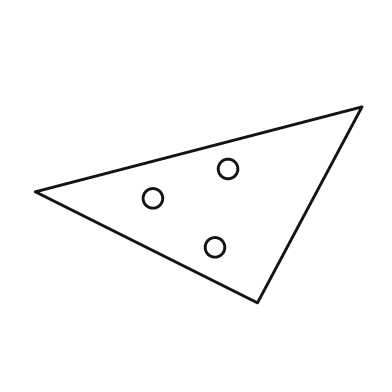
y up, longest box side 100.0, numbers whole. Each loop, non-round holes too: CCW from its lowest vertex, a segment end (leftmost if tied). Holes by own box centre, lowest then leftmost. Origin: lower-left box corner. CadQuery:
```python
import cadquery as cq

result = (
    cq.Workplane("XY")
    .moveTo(68.0, 0.0)
    .lineTo(100.0, 60.0)
    .lineTo(0.0, 34.0)
    .close()
    .moveTo(55.0, 17.0)
    .circle(3.0)
    .moveTo(36.0, 32.0)
    .circle(3.0)
    .moveTo(59.0, 41.0)
    .circle(3.0)
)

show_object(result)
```